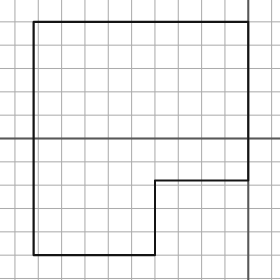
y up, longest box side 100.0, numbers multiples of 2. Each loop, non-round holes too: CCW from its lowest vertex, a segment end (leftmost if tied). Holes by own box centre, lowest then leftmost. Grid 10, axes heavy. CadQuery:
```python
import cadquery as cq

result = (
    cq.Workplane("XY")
    .moveTo(-92.0, -50.0)
    .lineTo(-40.0, -50.0)
    .lineTo(-40.0, -18.0)
    .lineTo(0.0, -18.0)
    .lineTo(0.0, 50.0)
    .lineTo(-92.0, 50.0)
    .close()
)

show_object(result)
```